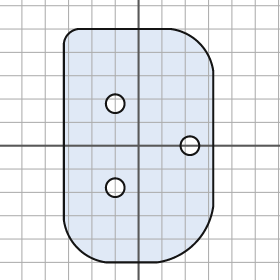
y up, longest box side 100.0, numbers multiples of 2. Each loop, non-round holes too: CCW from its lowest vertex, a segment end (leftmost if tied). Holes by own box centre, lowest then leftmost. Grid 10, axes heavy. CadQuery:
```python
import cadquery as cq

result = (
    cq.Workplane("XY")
    .moveTo(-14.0, -50.0)
    .lineTo(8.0, -50.0)
    .threePointArc((24.0, -42.0), (32.0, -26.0))
    .lineTo(32.0, 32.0)
    .threePointArc((26.0, 44.0), (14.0, 50.0))
    .lineTo(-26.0, 50.0)
    .threePointArc((-30.0, 48.0), (-32.0, 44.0))
    .lineTo(-32.0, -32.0)
    .threePointArc((-26.0, -44.0), (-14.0, -50.0))
    .close()
    .moveTo(-10.0, -18.0)
    .circle(4.0)
    .moveTo(22.0, 0.0)
    .circle(4.0)
    .moveTo(-10.0, 18.0)
    .circle(4.0)
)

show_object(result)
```